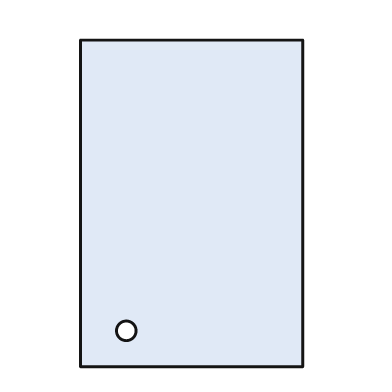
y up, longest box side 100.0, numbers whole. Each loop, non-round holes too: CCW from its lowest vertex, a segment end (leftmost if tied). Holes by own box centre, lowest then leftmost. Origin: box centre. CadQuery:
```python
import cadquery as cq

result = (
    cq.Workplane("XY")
    .moveTo(-34.0, -50.0)
    .lineTo(34.0, -50.0)
    .lineTo(34.0, 50.0)
    .lineTo(-34.0, 50.0)
    .close()
    .moveTo(-20.0, -39.0)
    .circle(3.0)
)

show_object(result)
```